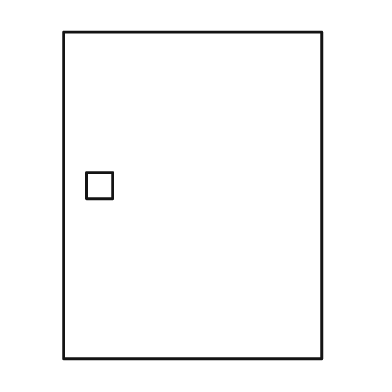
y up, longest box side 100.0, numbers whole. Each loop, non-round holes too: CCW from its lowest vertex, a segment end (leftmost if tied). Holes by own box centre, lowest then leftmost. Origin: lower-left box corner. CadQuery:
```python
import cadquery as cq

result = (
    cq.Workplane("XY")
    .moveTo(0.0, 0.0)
    .lineTo(79.0, 0.0)
    .lineTo(79.0, 100.0)
    .lineTo(0.0, 100.0)
    .close()
    .moveTo(7.0, 49.0)
    .lineTo(15.0, 49.0)
    .lineTo(15.0, 57.0)
    .lineTo(7.0, 57.0)
    .close()
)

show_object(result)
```